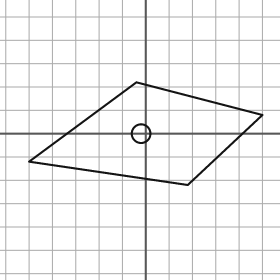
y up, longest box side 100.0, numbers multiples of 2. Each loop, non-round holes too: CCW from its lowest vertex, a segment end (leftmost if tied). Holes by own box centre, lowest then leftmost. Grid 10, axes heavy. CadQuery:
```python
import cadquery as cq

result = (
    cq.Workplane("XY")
    .moveTo(18.0, -22.0)
    .lineTo(50.0, 8.0)
    .lineTo(-4.0, 22.0)
    .lineTo(-50.0, -12.0)
    .close()
    .moveTo(-2.0, 0.0)
    .circle(4.0)
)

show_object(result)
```